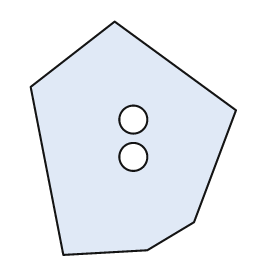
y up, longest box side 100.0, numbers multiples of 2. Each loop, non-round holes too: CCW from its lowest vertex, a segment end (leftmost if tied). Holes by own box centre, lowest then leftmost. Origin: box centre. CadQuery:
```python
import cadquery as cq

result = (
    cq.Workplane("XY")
    .moveTo(-30.0, -50.0)
    .lineTo(6.0, -48.0)
    .lineTo(26.0, -36.0)
    .lineTo(44.0, 12.0)
    .lineTo(-8.0, 50.0)
    .lineTo(-44.0, 22.0)
    .close()
    .moveTo(0.0, -8.0)
    .circle(6.0)
    .moveTo(0.0, 8.0)
    .circle(6.0)
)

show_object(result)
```